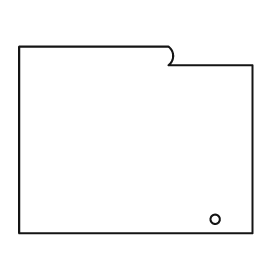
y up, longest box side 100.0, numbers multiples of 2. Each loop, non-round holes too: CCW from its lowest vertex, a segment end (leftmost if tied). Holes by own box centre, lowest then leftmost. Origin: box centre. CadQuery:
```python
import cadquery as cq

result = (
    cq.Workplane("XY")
    .moveTo(-50.0, -40.0)
    .lineTo(50.0, -40.0)
    .lineTo(50.0, 32.0)
    .lineTo(14.0, 32.0)
    .threePointArc((16.0, 36.0), (14.0, 40.0))
    .lineTo(-50.0, 40.0)
    .close()
    .moveTo(34.0, -34.0)
    .circle(2.0)
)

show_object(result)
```